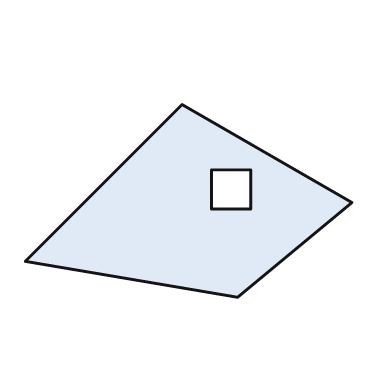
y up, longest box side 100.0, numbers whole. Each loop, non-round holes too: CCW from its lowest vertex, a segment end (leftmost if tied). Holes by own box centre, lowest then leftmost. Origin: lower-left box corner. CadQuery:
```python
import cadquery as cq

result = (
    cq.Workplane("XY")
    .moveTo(65.0, 0.0)
    .lineTo(100.0, 29.0)
    .lineTo(48.0, 59.0)
    .lineTo(0.0, 11.0)
    .close()
    .moveTo(57.0, 27.0)
    .lineTo(69.0, 27.0)
    .lineTo(69.0, 39.0)
    .lineTo(57.0, 39.0)
    .close()
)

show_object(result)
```